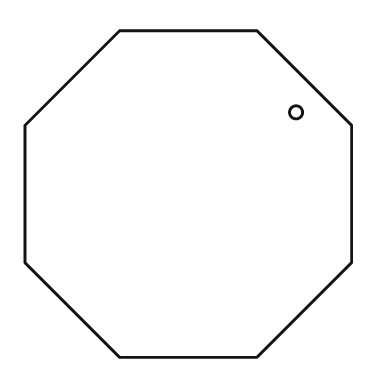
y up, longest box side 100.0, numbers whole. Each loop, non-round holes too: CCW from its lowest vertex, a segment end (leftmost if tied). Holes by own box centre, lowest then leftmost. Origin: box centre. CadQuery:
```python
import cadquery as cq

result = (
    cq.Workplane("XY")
    .moveTo(-21.0, -50.0)
    .lineTo(21.0, -50.0)
    .lineTo(50.0, -21.0)
    .lineTo(50.0, 21.0)
    .lineTo(21.0, 50.0)
    .lineTo(-21.0, 50.0)
    .lineTo(-50.0, 21.0)
    .lineTo(-50.0, -21.0)
    .close()
    .moveTo(33.0, 25.0)
    .circle(2.0)
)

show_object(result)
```